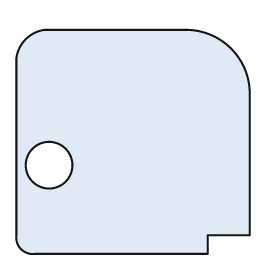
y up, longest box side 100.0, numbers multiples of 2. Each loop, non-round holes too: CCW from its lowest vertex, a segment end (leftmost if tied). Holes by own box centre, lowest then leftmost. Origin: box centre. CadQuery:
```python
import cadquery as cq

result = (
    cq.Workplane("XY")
    .moveTo(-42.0, -48.0)
    .lineTo(32.0, -48.0)
    .lineTo(32.0, -40.0)
    .lineTo(50.0, -40.0)
    .lineTo(50.0, 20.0)
    .threePointArc((42.0, 40.0), (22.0, 48.0))
    .lineTo(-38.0, 48.0)
    .threePointArc((-46.0, 44.0), (-50.0, 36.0))
    .lineTo(-50.0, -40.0)
    .threePointArc((-48.0, -46.0), (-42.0, -48.0))
    .close()
    .moveTo(-36.0, -10.0)
    .circle(10.0)
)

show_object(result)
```